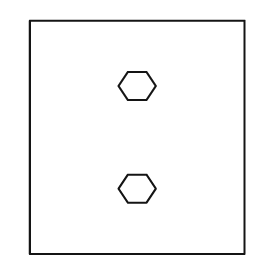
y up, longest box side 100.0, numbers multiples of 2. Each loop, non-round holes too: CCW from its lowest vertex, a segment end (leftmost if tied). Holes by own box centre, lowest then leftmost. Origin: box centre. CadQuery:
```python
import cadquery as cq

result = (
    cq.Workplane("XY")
    .moveTo(-46.0, -50.0)
    .lineTo(46.0, -50.0)
    .lineTo(46.0, 50.0)
    .lineTo(-46.0, 50.0)
    .close()
    .moveTo(-4.0, -28.0)
    .lineTo(4.0, -28.0)
    .lineTo(8.0, -22.0)
    .lineTo(4.0, -16.0)
    .lineTo(-4.0, -16.0)
    .lineTo(-8.0, -22.0)
    .close()
    .moveTo(-4.0, 16.0)
    .lineTo(4.0, 16.0)
    .lineTo(8.0, 22.0)
    .lineTo(4.0, 28.0)
    .lineTo(-4.0, 28.0)
    .lineTo(-8.0, 22.0)
    .close()
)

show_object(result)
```